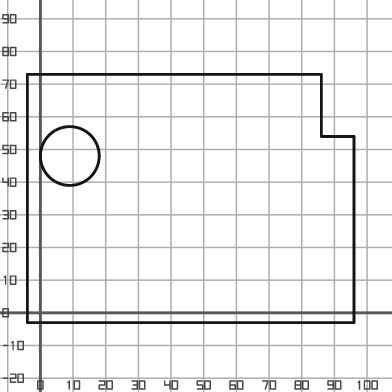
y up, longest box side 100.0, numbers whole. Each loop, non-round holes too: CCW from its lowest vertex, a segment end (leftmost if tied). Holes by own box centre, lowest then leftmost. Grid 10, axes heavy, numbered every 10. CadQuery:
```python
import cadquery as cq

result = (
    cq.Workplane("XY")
    .moveTo(-4.0, -3.0)
    .lineTo(96.0, -3.0)
    .lineTo(96.0, 54.0)
    .lineTo(86.0, 54.0)
    .lineTo(86.0, 73.0)
    .lineTo(-4.0, 73.0)
    .close()
    .moveTo(9.0, 48.0)
    .circle(9.0)
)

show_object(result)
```